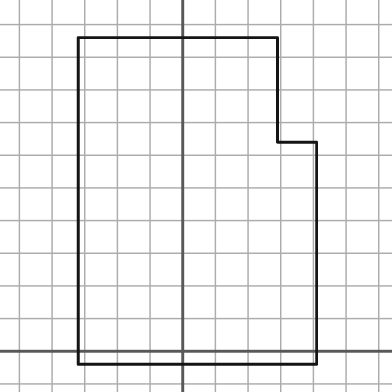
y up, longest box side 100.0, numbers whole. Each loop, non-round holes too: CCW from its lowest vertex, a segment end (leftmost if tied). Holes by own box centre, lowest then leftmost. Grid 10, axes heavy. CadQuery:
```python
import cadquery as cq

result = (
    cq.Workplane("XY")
    .moveTo(-32.0, -4.0)
    .lineTo(41.0, -4.0)
    .lineTo(41.0, 64.0)
    .lineTo(29.0, 64.0)
    .lineTo(29.0, 96.0)
    .lineTo(-32.0, 96.0)
    .close()
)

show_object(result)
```